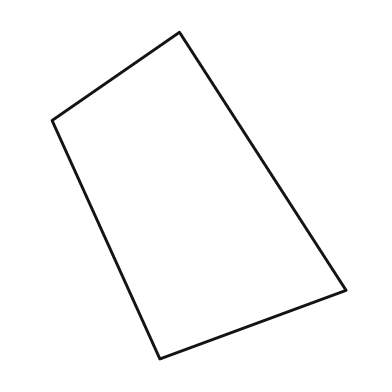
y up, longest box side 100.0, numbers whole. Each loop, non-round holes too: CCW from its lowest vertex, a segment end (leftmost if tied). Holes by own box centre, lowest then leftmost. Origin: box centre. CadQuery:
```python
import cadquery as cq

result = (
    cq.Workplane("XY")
    .moveTo(-12.0, -50.0)
    .lineTo(45.0, -29.0)
    .lineTo(-6.0, 50.0)
    .lineTo(-45.0, 23.0)
    .close()
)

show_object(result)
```